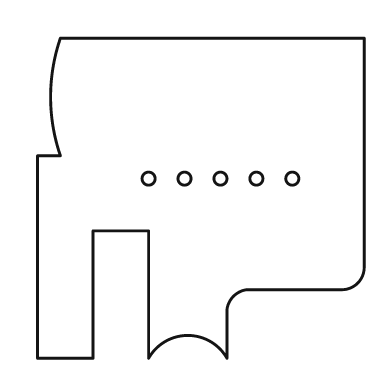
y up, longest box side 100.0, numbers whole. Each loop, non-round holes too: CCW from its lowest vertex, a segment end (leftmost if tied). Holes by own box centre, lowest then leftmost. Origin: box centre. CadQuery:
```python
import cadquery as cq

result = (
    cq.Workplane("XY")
    .moveTo(-50.0, -49.0)
    .lineTo(-33.0, -49.0)
    .lineTo(-33.0, -10.0)
    .lineTo(-16.0, -10.0)
    .lineTo(-16.0, -49.0)
    .threePointArc((-4.0, -42.0), (8.0, -49.0))
    .lineTo(8.0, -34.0)
    .threePointArc((10.0, -30.0), (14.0, -28.0))
    .lineTo(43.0, -28.0)
    .threePointArc((48.0, -26.0), (50.0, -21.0))
    .lineTo(50.0, 49.0)
    .lineTo(-43.0, 49.0)
    .threePointArc((-46.0, 31.0), (-43.0, 13.0))
    .lineTo(-50.0, 13.0)
    .close()
    .moveTo(-16.0, 6.0)
    .circle(2.0)
    .moveTo(-5.0, 6.0)
    .circle(2.0)
    .moveTo(6.0, 6.0)
    .circle(2.0)
    .moveTo(17.0, 6.0)
    .circle(2.0)
    .moveTo(28.0, 6.0)
    .circle(2.0)
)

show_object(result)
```